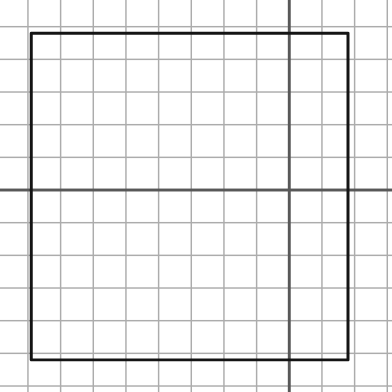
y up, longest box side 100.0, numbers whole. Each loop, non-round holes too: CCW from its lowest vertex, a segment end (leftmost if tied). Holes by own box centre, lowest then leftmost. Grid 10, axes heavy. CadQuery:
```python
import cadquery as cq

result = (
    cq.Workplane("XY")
    .moveTo(-79.0, -52.0)
    .lineTo(18.0, -52.0)
    .lineTo(18.0, 48.0)
    .lineTo(-79.0, 48.0)
    .close()
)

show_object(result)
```